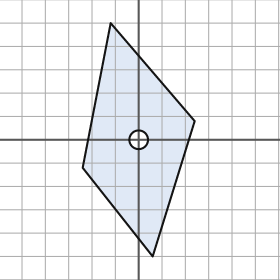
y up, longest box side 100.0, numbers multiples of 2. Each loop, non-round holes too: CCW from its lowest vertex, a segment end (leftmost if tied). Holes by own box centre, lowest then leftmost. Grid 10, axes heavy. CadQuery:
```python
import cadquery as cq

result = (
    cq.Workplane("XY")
    .moveTo(6.0, -50.0)
    .lineTo(24.0, 8.0)
    .lineTo(-12.0, 50.0)
    .lineTo(-24.0, -12.0)
    .close()
    .moveTo(0.0, 0.0)
    .circle(4.0)
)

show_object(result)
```